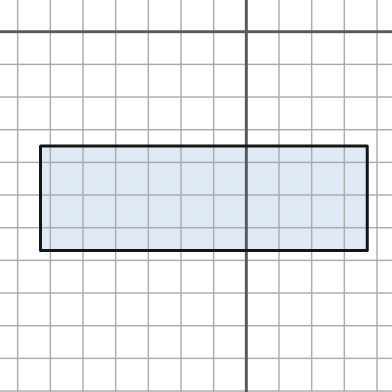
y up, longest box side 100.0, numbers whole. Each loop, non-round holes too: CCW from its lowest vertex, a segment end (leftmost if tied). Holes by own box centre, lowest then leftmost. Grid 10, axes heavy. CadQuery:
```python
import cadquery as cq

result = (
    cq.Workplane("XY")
    .moveTo(-63.0, -67.0)
    .lineTo(37.0, -67.0)
    .lineTo(37.0, -35.0)
    .lineTo(-63.0, -35.0)
    .close()
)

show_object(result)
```